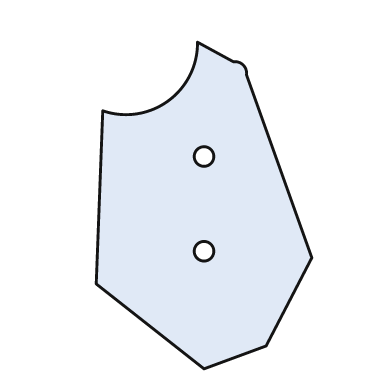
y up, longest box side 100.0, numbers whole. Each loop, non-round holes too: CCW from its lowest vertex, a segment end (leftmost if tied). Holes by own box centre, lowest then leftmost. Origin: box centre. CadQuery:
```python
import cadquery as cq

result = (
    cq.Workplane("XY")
    .moveTo(0.0, -50.0)
    .lineTo(19.0, -43.0)
    .lineTo(33.0, -16.0)
    .lineTo(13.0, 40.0)
    .threePointArc((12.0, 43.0), (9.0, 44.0))
    .lineTo(-2.0, 50.0)
    .threePointArc((-11.0, 32.0), (-31.0, 29.0))
    .lineTo(-33.0, -24.0)
    .close()
    .moveTo(0.0, -14.0)
    .circle(3.0)
    .moveTo(0.0, 15.0)
    .circle(3.0)
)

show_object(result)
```